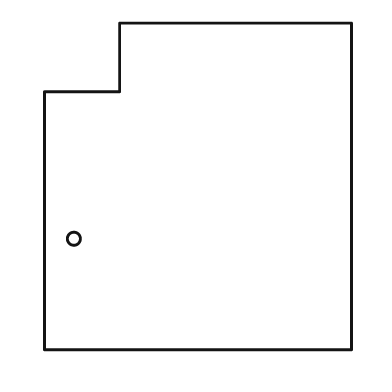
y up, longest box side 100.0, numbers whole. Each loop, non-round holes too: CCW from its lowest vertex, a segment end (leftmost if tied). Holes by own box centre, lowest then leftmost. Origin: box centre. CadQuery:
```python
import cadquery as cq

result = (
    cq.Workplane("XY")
    .moveTo(-47.0, -50.0)
    .lineTo(47.0, -50.0)
    .lineTo(47.0, 50.0)
    .lineTo(-24.0, 50.0)
    .lineTo(-24.0, 29.0)
    .lineTo(-47.0, 29.0)
    .close()
    .moveTo(-38.0, -16.0)
    .circle(2.0)
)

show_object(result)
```